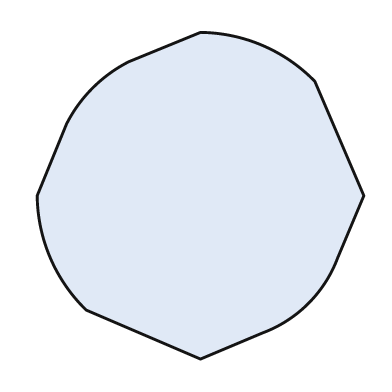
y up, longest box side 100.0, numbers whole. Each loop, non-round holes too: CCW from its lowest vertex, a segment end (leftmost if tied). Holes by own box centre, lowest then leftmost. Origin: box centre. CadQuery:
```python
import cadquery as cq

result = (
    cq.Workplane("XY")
    .moveTo(0.0, -50.0)
    .lineTo(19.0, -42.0)
    .threePointArc((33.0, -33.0), (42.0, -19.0))
    .lineTo(50.0, 0.0)
    .lineTo(35.0, 35.0)
    .threePointArc((19.0, 46.0), (0.0, 50.0))
    .lineTo(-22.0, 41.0)
    .threePointArc((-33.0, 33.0), (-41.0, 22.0))
    .lineTo(-50.0, 0.0)
    .threePointArc((-46.0, -19.0), (-35.0, -35.0))
    .close()
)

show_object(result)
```